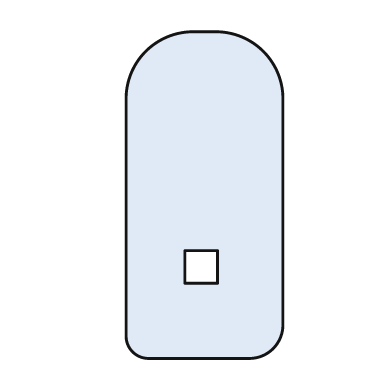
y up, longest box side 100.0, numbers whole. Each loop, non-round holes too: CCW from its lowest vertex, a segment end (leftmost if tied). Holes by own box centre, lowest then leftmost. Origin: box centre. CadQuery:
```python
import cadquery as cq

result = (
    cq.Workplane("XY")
    .moveTo(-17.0, -50.0)
    .lineTo(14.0, -50.0)
    .threePointArc((21.0, -47.0), (24.0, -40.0))
    .lineTo(24.0, 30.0)
    .threePointArc((18.0, 44.0), (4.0, 50.0))
    .lineTo(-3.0, 50.0)
    .threePointArc((-18.0, 44.0), (-24.0, 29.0))
    .lineTo(-24.0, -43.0)
    .threePointArc((-22.0, -48.0), (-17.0, -50.0))
    .close()
    .moveTo(-6.0, -27.0)
    .lineTo(4.0, -27.0)
    .lineTo(4.0, -17.0)
    .lineTo(-6.0, -17.0)
    .close()
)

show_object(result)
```